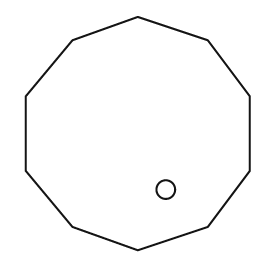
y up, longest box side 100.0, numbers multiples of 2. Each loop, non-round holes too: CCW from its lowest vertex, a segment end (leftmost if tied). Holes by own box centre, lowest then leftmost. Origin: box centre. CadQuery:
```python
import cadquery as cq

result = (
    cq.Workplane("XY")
    .moveTo(0.0, -50.0)
    .lineTo(30.0, -40.0)
    .lineTo(48.0, -16.0)
    .lineTo(48.0, 16.0)
    .lineTo(30.0, 40.0)
    .lineTo(0.0, 50.0)
    .lineTo(-28.0, 40.0)
    .lineTo(-48.0, 16.0)
    .lineTo(-48.0, -16.0)
    .lineTo(-28.0, -40.0)
    .close()
    .moveTo(12.0, -24.0)
    .circle(4.0)
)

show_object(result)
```